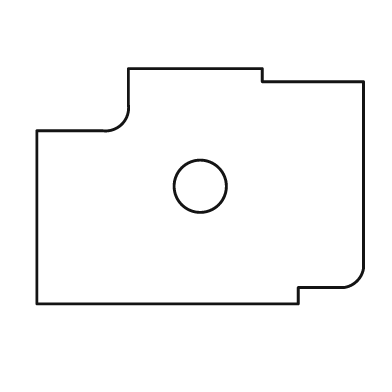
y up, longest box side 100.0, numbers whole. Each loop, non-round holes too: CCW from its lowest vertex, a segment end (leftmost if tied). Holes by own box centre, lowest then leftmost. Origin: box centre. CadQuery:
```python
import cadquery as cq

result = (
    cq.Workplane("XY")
    .moveTo(-50.0, -36.0)
    .lineTo(30.0, -36.0)
    .lineTo(30.0, -31.0)
    .lineTo(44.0, -31.0)
    .threePointArc((48.0, -29.0), (50.0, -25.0))
    .lineTo(50.0, 32.0)
    .lineTo(19.0, 32.0)
    .lineTo(19.0, 36.0)
    .lineTo(-22.0, 36.0)
    .lineTo(-22.0, 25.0)
    .threePointArc((-24.0, 19.0), (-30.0, 17.0))
    .lineTo(-50.0, 17.0)
    .close()
    .moveTo(0.0, 0.0)
    .circle(8.0)
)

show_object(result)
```